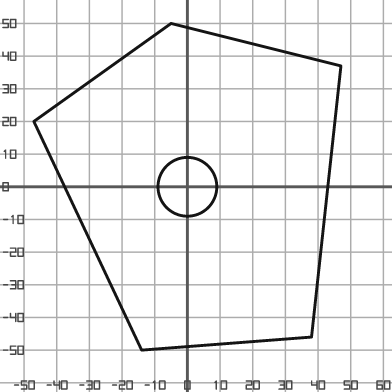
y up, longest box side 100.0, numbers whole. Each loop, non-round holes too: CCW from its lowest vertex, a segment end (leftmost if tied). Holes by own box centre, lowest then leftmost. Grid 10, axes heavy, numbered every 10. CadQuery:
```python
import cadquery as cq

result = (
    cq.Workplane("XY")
    .moveTo(-14.0, -50.0)
    .lineTo(38.0, -46.0)
    .lineTo(47.0, 37.0)
    .lineTo(-5.0, 50.0)
    .lineTo(-47.0, 20.0)
    .close()
    .moveTo(0.0, 0.0)
    .circle(9.0)
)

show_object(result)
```